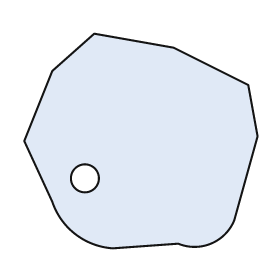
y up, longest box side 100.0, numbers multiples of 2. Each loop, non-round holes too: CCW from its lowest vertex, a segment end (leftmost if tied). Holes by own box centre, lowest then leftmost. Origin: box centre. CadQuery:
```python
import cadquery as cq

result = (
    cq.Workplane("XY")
    .moveTo(-12.0, -46.0)
    .lineTo(16.0, -44.0)
    .threePointArc((30.0, -44.0), (40.0, -34.0))
    .lineTo(50.0, 2.0)
    .lineTo(46.0, 24.0)
    .lineTo(14.0, 40.0)
    .lineTo(-20.0, 46.0)
    .lineTo(-38.0, 30.0)
    .lineTo(-50.0, 0.0)
    .lineTo(-38.0, -26.0)
    .threePointArc((-28.0, -40.0), (-12.0, -46.0))
    .close()
    .moveTo(-24.0, -16.0)
    .circle(6.0)
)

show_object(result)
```